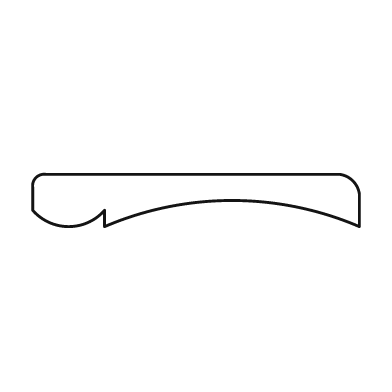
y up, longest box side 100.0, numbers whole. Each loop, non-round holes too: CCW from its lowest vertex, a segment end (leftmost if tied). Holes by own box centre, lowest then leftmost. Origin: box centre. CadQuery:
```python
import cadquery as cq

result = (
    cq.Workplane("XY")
    .moveTo(-28.0, -8.0)
    .threePointArc((11.0, 0.0), (50.0, -8.0))
    .lineTo(50.0, 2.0)
    .threePointArc((48.0, 6.0), (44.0, 8.0))
    .lineTo(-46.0, 8.0)
    .threePointArc((-49.0, 7.0), (-50.0, 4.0))
    .lineTo(-50.0, -3.0)
    .threePointArc((-39.0, -8.0), (-28.0, -3.0))
    .close()
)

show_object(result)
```